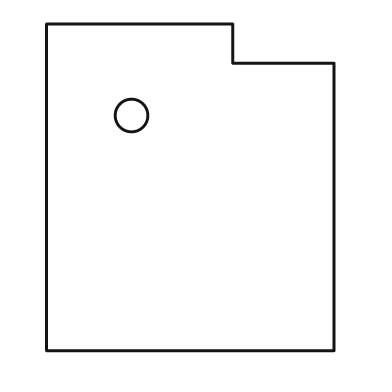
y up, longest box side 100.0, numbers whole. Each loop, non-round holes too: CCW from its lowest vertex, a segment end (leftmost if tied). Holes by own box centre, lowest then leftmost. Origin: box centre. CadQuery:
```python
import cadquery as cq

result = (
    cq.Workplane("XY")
    .moveTo(-44.0, -50.0)
    .lineTo(44.0, -50.0)
    .lineTo(44.0, 38.0)
    .lineTo(13.0, 38.0)
    .lineTo(13.0, 50.0)
    .lineTo(-44.0, 50.0)
    .close()
    .moveTo(-18.0, 22.0)
    .circle(5.0)
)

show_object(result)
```